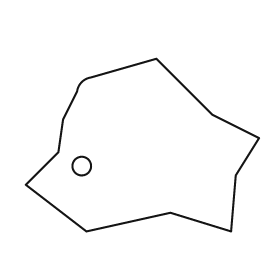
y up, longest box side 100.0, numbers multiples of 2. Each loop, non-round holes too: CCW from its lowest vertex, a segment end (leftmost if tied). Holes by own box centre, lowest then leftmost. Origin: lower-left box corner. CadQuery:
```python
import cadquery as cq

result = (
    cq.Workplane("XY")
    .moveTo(26.0, 0.0)
    .lineTo(62.0, 8.0)
    .lineTo(88.0, 0.0)
    .lineTo(90.0, 24.0)
    .lineTo(100.0, 40.0)
    .lineTo(80.0, 50.0)
    .lineTo(56.0, 74.0)
    .lineTo(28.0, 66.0)
    .threePointArc((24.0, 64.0), (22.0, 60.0))
    .lineTo(16.0, 48.0)
    .lineTo(14.0, 34.0)
    .lineTo(0.0, 20.0)
    .close()
    .moveTo(24.0, 28.0)
    .circle(4.0)
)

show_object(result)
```